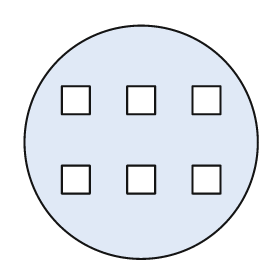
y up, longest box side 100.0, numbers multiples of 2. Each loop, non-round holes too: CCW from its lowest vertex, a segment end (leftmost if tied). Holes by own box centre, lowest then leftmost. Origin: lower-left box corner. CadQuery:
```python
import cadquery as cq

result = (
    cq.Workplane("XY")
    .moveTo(50.0, 50.0)
    .circle(50.0)
    .moveTo(16.0, 28.0)
    .lineTo(28.0, 28.0)
    .lineTo(28.0, 40.0)
    .lineTo(16.0, 40.0)
    .close()
    .moveTo(44.0, 28.0)
    .lineTo(56.0, 28.0)
    .lineTo(56.0, 40.0)
    .lineTo(44.0, 40.0)
    .close()
    .moveTo(72.0, 28.0)
    .lineTo(84.0, 28.0)
    .lineTo(84.0, 40.0)
    .lineTo(72.0, 40.0)
    .close()
    .moveTo(16.0, 62.0)
    .lineTo(28.0, 62.0)
    .lineTo(28.0, 74.0)
    .lineTo(16.0, 74.0)
    .close()
    .moveTo(44.0, 62.0)
    .lineTo(56.0, 62.0)
    .lineTo(56.0, 74.0)
    .lineTo(44.0, 74.0)
    .close()
    .moveTo(72.0, 62.0)
    .lineTo(84.0, 62.0)
    .lineTo(84.0, 74.0)
    .lineTo(72.0, 74.0)
    .close()
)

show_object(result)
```